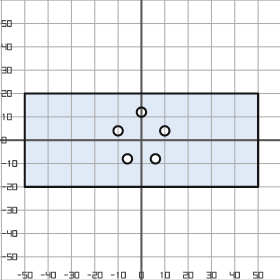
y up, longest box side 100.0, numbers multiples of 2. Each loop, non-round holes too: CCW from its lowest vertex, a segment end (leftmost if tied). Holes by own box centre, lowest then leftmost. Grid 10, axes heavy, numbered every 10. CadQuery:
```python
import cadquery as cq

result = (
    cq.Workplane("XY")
    .moveTo(-50.0, -20.0)
    .lineTo(50.0, -20.0)
    .lineTo(50.0, 20.0)
    .lineTo(-50.0, 20.0)
    .close()
    .moveTo(-6.0, -8.0)
    .circle(2.0)
    .moveTo(6.0, -8.0)
    .circle(2.0)
    .moveTo(-10.0, 4.0)
    .circle(2.0)
    .moveTo(10.0, 4.0)
    .circle(2.0)
    .moveTo(0.0, 12.0)
    .circle(2.0)
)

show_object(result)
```